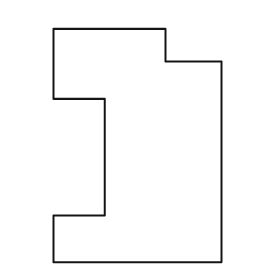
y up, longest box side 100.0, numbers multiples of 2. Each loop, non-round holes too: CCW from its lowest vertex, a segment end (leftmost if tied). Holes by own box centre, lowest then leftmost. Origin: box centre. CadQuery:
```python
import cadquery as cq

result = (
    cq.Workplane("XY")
    .moveTo(-36.0, -50.0)
    .lineTo(36.0, -50.0)
    .lineTo(36.0, 36.0)
    .lineTo(12.0, 36.0)
    .lineTo(12.0, 50.0)
    .lineTo(-36.0, 50.0)
    .lineTo(-36.0, 20.0)
    .lineTo(-14.0, 20.0)
    .lineTo(-14.0, -30.0)
    .lineTo(-36.0, -30.0)
    .close()
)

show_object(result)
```